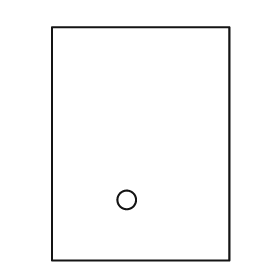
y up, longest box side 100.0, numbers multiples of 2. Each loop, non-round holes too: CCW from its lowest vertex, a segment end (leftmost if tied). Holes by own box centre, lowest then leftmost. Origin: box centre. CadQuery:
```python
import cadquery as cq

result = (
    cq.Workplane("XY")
    .moveTo(-38.0, -50.0)
    .lineTo(38.0, -50.0)
    .lineTo(38.0, 50.0)
    .lineTo(-38.0, 50.0)
    .close()
    .moveTo(-6.0, -24.0)
    .circle(4.0)
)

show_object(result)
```